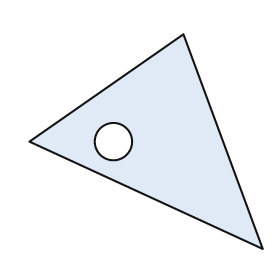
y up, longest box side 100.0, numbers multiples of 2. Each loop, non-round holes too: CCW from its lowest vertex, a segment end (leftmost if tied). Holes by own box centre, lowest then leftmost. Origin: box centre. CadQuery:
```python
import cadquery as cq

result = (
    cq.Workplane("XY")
    .moveTo(50.0, -46.0)
    .lineTo(16.0, 46.0)
    .lineTo(-50.0, 0.0)
    .close()
    .moveTo(-14.0, 0.0)
    .circle(8.0)
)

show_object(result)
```